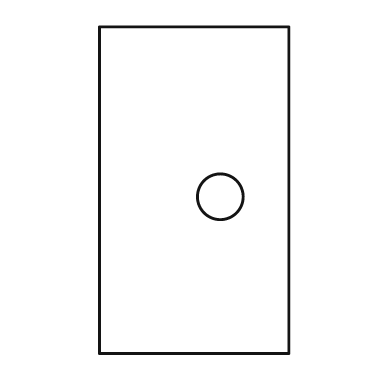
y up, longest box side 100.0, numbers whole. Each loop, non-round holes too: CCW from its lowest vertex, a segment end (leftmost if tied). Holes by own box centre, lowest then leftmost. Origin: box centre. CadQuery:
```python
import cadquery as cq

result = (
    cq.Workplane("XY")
    .moveTo(-29.0, -50.0)
    .lineTo(29.0, -50.0)
    .lineTo(29.0, 50.0)
    .lineTo(-29.0, 50.0)
    .close()
    .moveTo(8.0, -2.0)
    .circle(7.0)
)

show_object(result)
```